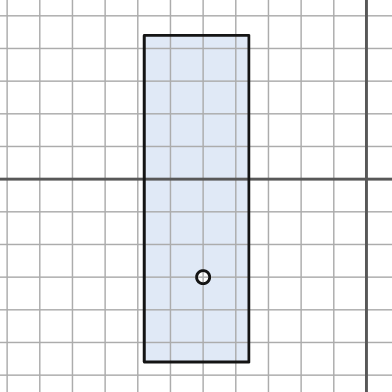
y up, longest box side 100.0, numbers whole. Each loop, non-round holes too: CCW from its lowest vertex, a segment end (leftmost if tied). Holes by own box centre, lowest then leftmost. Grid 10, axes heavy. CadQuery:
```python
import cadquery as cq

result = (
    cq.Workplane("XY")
    .moveTo(-68.0, -56.0)
    .lineTo(-36.0, -56.0)
    .lineTo(-36.0, 44.0)
    .lineTo(-68.0, 44.0)
    .close()
    .moveTo(-50.0, -30.0)
    .circle(2.0)
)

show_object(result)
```